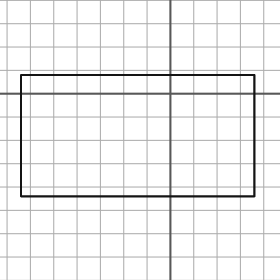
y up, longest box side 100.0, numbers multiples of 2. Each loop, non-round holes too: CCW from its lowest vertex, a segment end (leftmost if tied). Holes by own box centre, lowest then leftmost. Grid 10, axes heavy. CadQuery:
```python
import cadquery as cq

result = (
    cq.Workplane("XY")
    .moveTo(-64.0, -44.0)
    .lineTo(36.0, -44.0)
    .lineTo(36.0, 8.0)
    .lineTo(-64.0, 8.0)
    .close()
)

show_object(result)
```